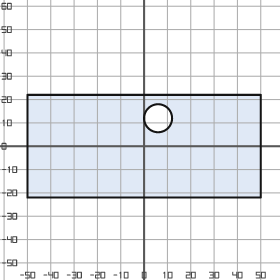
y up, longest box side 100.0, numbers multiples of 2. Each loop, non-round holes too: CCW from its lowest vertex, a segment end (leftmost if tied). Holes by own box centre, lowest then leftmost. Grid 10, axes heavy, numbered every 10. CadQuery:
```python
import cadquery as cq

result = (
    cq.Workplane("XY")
    .moveTo(-50.0, -22.0)
    .lineTo(50.0, -22.0)
    .lineTo(50.0, 22.0)
    .lineTo(-50.0, 22.0)
    .close()
    .moveTo(6.0, 12.0)
    .circle(6.0)
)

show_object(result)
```